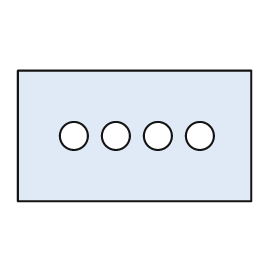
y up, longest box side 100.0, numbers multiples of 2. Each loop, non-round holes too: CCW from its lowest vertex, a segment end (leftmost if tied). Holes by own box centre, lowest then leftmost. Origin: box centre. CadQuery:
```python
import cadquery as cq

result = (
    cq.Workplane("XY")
    .moveTo(-50.0, -28.0)
    .lineTo(50.0, -28.0)
    .lineTo(50.0, 28.0)
    .lineTo(-50.0, 28.0)
    .close()
    .moveTo(-26.0, 0.0)
    .circle(6.0)
    .moveTo(-8.0, 0.0)
    .circle(6.0)
    .moveTo(10.0, 0.0)
    .circle(6.0)
    .moveTo(28.0, 0.0)
    .circle(6.0)
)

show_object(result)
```